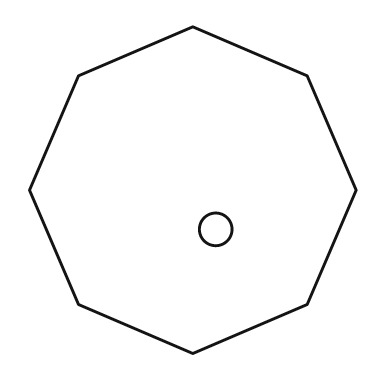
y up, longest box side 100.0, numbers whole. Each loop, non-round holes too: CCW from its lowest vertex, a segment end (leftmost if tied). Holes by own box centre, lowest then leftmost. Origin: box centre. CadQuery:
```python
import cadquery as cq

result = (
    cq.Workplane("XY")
    .moveTo(0.0, -50.0)
    .lineTo(35.0, -35.0)
    .lineTo(50.0, 0.0)
    .lineTo(35.0, 35.0)
    .lineTo(0.0, 50.0)
    .lineTo(-35.0, 35.0)
    .lineTo(-50.0, 0.0)
    .lineTo(-35.0, -35.0)
    .close()
    .moveTo(7.0, -12.0)
    .circle(5.0)
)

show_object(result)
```